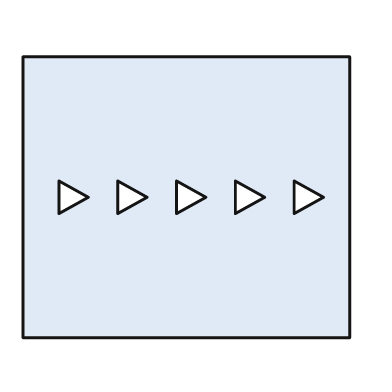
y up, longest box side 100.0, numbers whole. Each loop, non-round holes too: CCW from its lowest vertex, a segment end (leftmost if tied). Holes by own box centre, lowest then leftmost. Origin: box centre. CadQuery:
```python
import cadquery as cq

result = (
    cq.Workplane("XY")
    .moveTo(-50.0, -43.0)
    .lineTo(50.0, -43.0)
    .lineTo(50.0, 43.0)
    .lineTo(-50.0, 43.0)
    .close()
    .moveTo(-39.0, -5.0)
    .lineTo(-30.0, 0.0)
    .lineTo(-39.0, 5.0)
    .close()
    .moveTo(-21.0, -5.0)
    .lineTo(-12.0, 0.0)
    .lineTo(-21.0, 5.0)
    .close()
    .moveTo(-3.0, -5.0)
    .lineTo(6.0, 0.0)
    .lineTo(-3.0, 5.0)
    .close()
    .moveTo(15.0, -5.0)
    .lineTo(24.0, 0.0)
    .lineTo(15.0, 5.0)
    .close()
    .moveTo(33.0, -5.0)
    .lineTo(42.0, 0.0)
    .lineTo(33.0, 5.0)
    .close()
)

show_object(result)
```